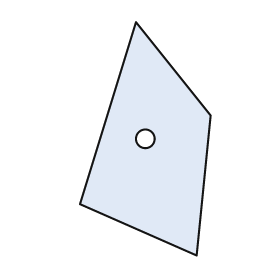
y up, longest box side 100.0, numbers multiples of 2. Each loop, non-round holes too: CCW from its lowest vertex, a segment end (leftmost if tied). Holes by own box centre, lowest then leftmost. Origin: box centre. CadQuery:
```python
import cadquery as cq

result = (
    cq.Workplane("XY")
    .moveTo(22.0, -50.0)
    .lineTo(28.0, 10.0)
    .lineTo(-4.0, 50.0)
    .lineTo(-28.0, -28.0)
    .close()
    .moveTo(0.0, 0.0)
    .circle(4.0)
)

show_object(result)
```